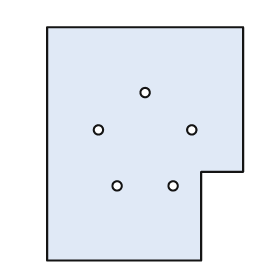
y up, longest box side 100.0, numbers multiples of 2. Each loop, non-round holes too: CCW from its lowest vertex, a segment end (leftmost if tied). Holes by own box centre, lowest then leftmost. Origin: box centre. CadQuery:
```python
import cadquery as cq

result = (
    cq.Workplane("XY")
    .moveTo(-42.0, -50.0)
    .lineTo(24.0, -50.0)
    .lineTo(24.0, -12.0)
    .lineTo(42.0, -12.0)
    .lineTo(42.0, 50.0)
    .lineTo(-42.0, 50.0)
    .close()
    .moveTo(-12.0, -18.0)
    .circle(2.0)
    .moveTo(12.0, -18.0)
    .circle(2.0)
    .moveTo(-20.0, 6.0)
    .circle(2.0)
    .moveTo(20.0, 6.0)
    .circle(2.0)
    .moveTo(0.0, 22.0)
    .circle(2.0)
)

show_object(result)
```